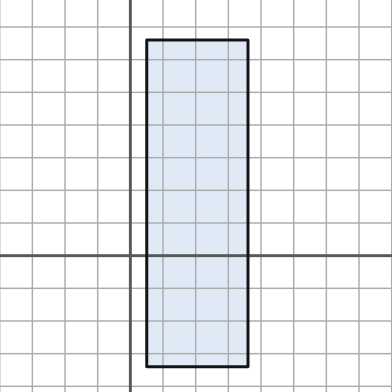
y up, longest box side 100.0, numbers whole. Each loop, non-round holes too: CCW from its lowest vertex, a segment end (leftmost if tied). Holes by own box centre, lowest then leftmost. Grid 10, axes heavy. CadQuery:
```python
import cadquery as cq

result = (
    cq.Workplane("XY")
    .moveTo(5.0, -34.0)
    .lineTo(36.0, -34.0)
    .lineTo(36.0, 66.0)
    .lineTo(5.0, 66.0)
    .close()
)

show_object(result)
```